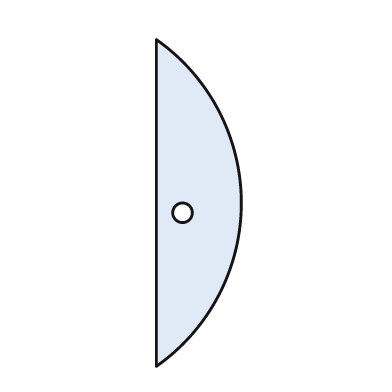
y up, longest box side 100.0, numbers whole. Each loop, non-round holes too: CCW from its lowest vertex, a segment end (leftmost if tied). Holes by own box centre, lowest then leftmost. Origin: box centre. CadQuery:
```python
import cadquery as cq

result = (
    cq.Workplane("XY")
    .moveTo(-13.0, -50.0)
    .threePointArc((13.0, 0.0), (-13.0, 50.0))
    .close()
    .moveTo(-5.0, -3.0)
    .circle(3.0)
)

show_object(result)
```